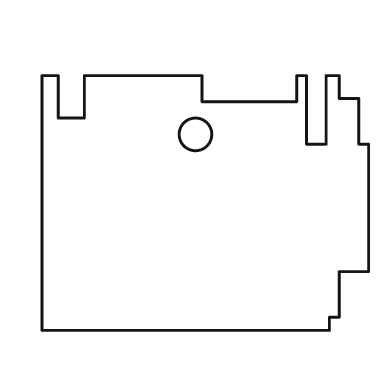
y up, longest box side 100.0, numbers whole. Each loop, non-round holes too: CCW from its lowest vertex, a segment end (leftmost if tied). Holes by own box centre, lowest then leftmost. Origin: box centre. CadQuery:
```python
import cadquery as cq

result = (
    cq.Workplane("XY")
    .moveTo(-50.0, -39.0)
    .lineTo(38.0, -39.0)
    .lineTo(38.0, -35.0)
    .lineTo(41.0, -35.0)
    .lineTo(41.0, -21.0)
    .lineTo(50.0, -21.0)
    .lineTo(50.0, 18.0)
    .lineTo(47.0, 18.0)
    .lineTo(47.0, 32.0)
    .lineTo(41.0, 32.0)
    .lineTo(41.0, 39.0)
    .lineTo(37.0, 39.0)
    .lineTo(37.0, 18.0)
    .lineTo(31.0, 18.0)
    .lineTo(31.0, 39.0)
    .lineTo(28.0, 39.0)
    .lineTo(28.0, 31.0)
    .lineTo(-1.0, 31.0)
    .lineTo(-1.0, 39.0)
    .lineTo(-37.0, 39.0)
    .lineTo(-37.0, 26.0)
    .lineTo(-45.0, 26.0)
    .lineTo(-45.0, 39.0)
    .lineTo(-50.0, 39.0)
    .close()
    .moveTo(-3.0, 21.0)
    .circle(5.0)
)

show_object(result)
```